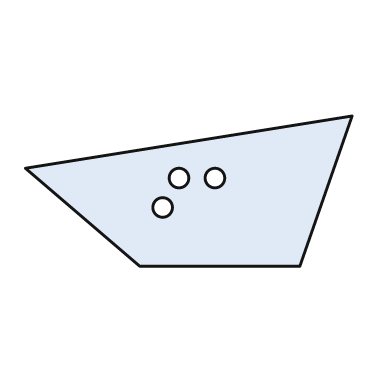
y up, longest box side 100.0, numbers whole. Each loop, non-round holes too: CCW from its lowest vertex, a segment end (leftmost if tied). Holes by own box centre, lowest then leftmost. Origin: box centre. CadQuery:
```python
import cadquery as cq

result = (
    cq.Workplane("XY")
    .moveTo(-15.0, -23.0)
    .lineTo(34.0, -23.0)
    .lineTo(50.0, 23.0)
    .lineTo(-50.0, 7.0)
    .close()
    .moveTo(-8.0, -5.0)
    .circle(3.0)
    .moveTo(-3.0, 4.0)
    .circle(3.0)
    .moveTo(8.0, 4.0)
    .circle(3.0)
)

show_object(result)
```